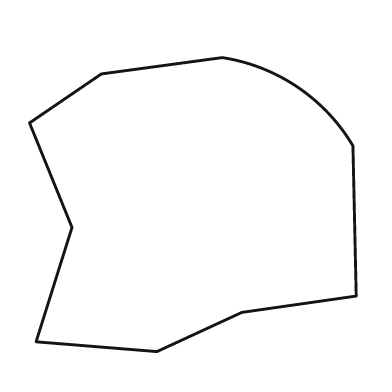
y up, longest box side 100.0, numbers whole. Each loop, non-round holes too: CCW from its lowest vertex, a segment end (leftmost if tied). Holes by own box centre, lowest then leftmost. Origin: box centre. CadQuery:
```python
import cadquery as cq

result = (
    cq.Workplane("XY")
    .moveTo(-11.0, -45.0)
    .lineTo(15.0, -33.0)
    .lineTo(50.0, -28.0)
    .lineTo(49.0, 18.0)
    .threePointArc((32.0, 36.0), (9.0, 45.0))
    .lineTo(-28.0, 40.0)
    .lineTo(-50.0, 25.0)
    .lineTo(-37.0, -7.0)
    .lineTo(-48.0, -42.0)
    .close()
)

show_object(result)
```